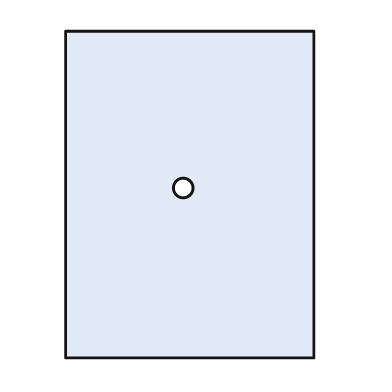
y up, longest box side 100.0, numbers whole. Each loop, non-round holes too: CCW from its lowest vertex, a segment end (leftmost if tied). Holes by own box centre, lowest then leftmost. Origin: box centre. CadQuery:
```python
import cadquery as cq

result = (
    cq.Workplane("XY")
    .moveTo(-38.0, -50.0)
    .lineTo(38.0, -50.0)
    .lineTo(38.0, 50.0)
    .lineTo(-38.0, 50.0)
    .close()
    .moveTo(-2.0, 2.0)
    .circle(3.0)
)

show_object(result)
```